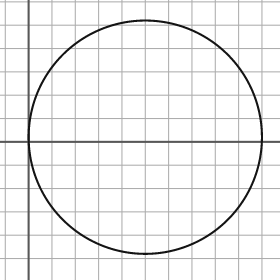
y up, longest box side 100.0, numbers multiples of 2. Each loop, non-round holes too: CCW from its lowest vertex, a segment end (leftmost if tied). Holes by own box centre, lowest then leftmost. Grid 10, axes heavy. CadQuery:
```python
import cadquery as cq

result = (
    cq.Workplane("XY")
    .moveTo(50.0, 2.0)
    .circle(50.0)
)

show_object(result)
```